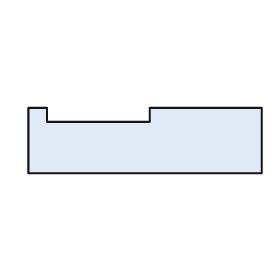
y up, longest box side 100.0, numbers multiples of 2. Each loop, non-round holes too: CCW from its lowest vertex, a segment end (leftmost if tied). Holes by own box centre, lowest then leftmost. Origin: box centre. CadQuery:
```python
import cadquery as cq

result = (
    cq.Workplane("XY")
    .moveTo(-50.0, -14.0)
    .lineTo(50.0, -14.0)
    .lineTo(50.0, 14.0)
    .lineTo(2.0, 14.0)
    .lineTo(2.0, 8.0)
    .lineTo(-42.0, 8.0)
    .lineTo(-42.0, 14.0)
    .lineTo(-50.0, 14.0)
    .close()
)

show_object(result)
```